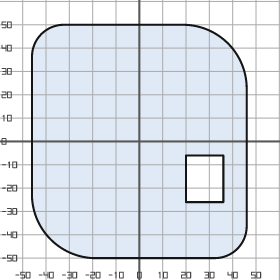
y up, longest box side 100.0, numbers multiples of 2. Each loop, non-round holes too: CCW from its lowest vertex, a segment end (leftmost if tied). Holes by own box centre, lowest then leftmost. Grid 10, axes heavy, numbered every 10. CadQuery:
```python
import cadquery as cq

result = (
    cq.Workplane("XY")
    .moveTo(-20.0, -50.0)
    .lineTo(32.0, -50.0)
    .threePointArc((42.0, -46.0), (46.0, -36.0))
    .lineTo(46.0, 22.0)
    .threePointArc((38.0, 42.0), (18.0, 50.0))
    .lineTo(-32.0, 50.0)
    .threePointArc((-42.0, 46.0), (-46.0, 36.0))
    .lineTo(-46.0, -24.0)
    .threePointArc((-38.0, -42.0), (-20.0, -50.0))
    .close()
    .moveTo(20.0, -26.0)
    .lineTo(36.0, -26.0)
    .lineTo(36.0, -6.0)
    .lineTo(20.0, -6.0)
    .close()
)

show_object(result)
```